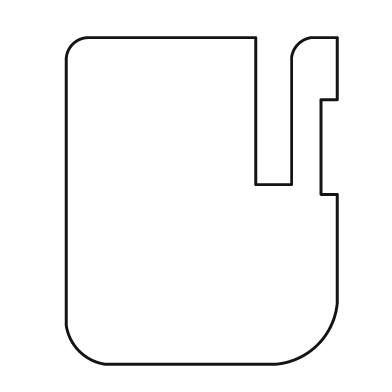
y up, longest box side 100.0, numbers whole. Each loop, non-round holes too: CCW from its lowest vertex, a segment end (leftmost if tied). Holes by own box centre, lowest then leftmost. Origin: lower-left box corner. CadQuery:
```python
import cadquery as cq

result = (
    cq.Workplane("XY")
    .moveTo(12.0, 0.0)
    .lineTo(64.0, 0.0)
    .threePointArc((77.0, 6.0), (83.0, 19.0))
    .lineTo(83.0, 52.0)
    .lineTo(78.0, 52.0)
    .lineTo(78.0, 81.0)
    .lineTo(83.0, 81.0)
    .lineTo(83.0, 100.0)
    .lineTo(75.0, 100.0)
    .threePointArc((71.0, 98.0), (69.0, 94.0))
    .lineTo(69.0, 55.0)
    .lineTo(58.0, 55.0)
    .lineTo(58.0, 100.0)
    .lineTo(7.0, 100.0)
    .threePointArc((2.0, 98.0), (0.0, 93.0))
    .lineTo(0.0, 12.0)
    .threePointArc((4.0, 4.0), (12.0, 0.0))
    .close()
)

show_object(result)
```